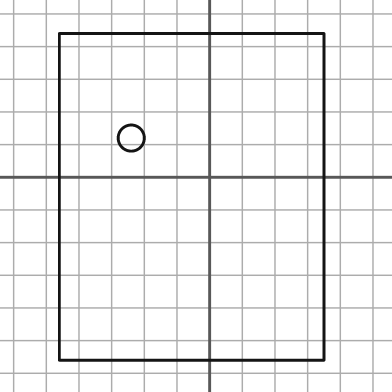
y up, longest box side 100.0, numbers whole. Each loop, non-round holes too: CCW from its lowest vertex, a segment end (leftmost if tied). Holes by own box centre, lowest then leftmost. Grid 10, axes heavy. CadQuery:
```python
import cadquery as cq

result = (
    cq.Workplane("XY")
    .moveTo(-46.0, -56.0)
    .lineTo(35.0, -56.0)
    .lineTo(35.0, 44.0)
    .lineTo(-46.0, 44.0)
    .close()
    .moveTo(-24.0, 12.0)
    .circle(4.0)
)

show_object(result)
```